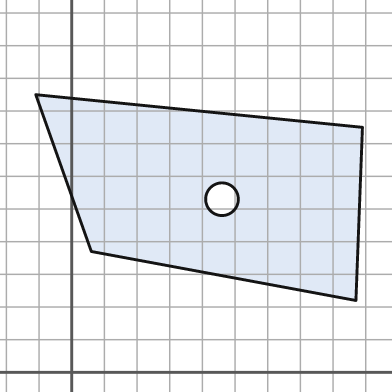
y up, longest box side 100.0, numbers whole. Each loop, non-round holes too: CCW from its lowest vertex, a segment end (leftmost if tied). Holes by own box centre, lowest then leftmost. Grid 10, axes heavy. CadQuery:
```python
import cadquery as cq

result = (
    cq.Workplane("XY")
    .moveTo(87.0, 22.0)
    .lineTo(89.0, 75.0)
    .lineTo(-11.0, 85.0)
    .lineTo(6.0, 37.0)
    .close()
    .moveTo(46.0, 53.0)
    .circle(5.0)
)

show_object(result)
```